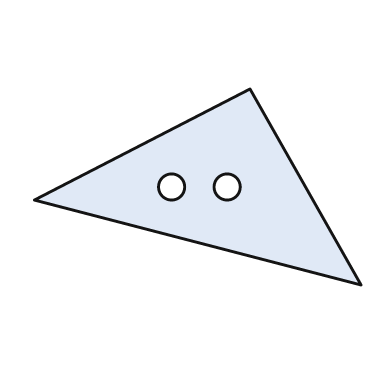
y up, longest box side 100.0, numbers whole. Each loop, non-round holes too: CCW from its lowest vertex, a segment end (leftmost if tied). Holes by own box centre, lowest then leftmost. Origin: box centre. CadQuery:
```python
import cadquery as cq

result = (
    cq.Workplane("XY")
    .moveTo(50.0, -30.0)
    .lineTo(16.0, 30.0)
    .lineTo(-50.0, -4.0)
    .close()
    .moveTo(-8.0, 0.0)
    .circle(4.0)
    .moveTo(9.0, 0.0)
    .circle(4.0)
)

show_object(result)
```